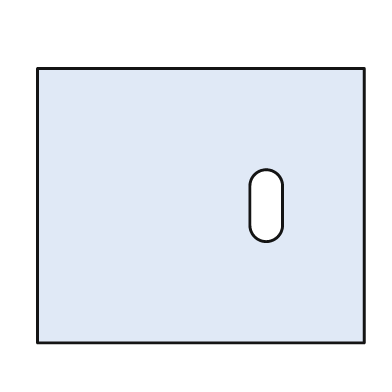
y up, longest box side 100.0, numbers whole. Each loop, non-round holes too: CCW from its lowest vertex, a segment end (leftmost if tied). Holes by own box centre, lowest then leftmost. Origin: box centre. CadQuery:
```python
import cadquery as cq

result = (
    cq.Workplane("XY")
    .moveTo(-50.0, -42.0)
    .lineTo(50.0, -42.0)
    .lineTo(50.0, 42.0)
    .lineTo(-50.0, 42.0)
    .close()
    .moveTo(15.0, -6.0)
    .threePointArc((20.0, -11.0), (25.0, -6.0))
    .lineTo(25.0, 6.0)
    .threePointArc((20.0, 11.0), (15.0, 6.0))
    .close()
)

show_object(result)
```